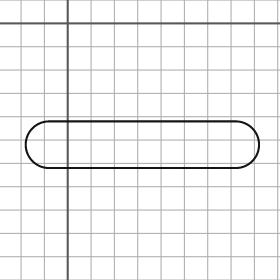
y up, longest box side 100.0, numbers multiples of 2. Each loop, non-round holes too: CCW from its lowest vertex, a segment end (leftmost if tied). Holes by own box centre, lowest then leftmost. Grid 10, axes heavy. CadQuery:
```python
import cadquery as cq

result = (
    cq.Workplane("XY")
    .moveTo(-8.0, -62.0)
    .lineTo(72.0, -62.0)
    .threePointArc((82.0, -52.0), (72.0, -42.0))
    .lineTo(-8.0, -42.0)
    .threePointArc((-18.0, -52.0), (-8.0, -62.0))
    .close()
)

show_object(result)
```